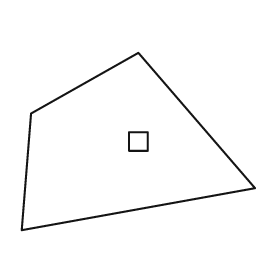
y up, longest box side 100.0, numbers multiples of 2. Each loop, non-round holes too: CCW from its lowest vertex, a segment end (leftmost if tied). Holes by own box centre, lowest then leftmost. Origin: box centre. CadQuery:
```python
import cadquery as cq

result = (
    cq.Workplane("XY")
    .moveTo(-50.0, -38.0)
    .lineTo(50.0, -20.0)
    .lineTo(0.0, 38.0)
    .lineTo(-46.0, 12.0)
    .close()
    .moveTo(-4.0, -4.0)
    .lineTo(4.0, -4.0)
    .lineTo(4.0, 4.0)
    .lineTo(-4.0, 4.0)
    .close()
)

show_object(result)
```